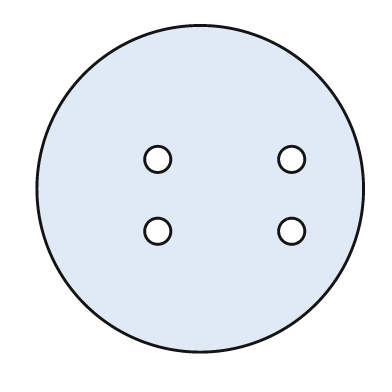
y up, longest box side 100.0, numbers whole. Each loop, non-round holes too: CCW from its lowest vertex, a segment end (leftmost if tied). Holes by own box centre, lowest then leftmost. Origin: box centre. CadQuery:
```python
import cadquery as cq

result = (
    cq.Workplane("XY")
    .moveTo(0.0, 0.0)
    .circle(50.0)
    .moveTo(-13.0, -13.0)
    .circle(4.0)
    .moveTo(28.0, -13.0)
    .circle(4.0)
    .moveTo(-13.0, 9.0)
    .circle(4.0)
    .moveTo(28.0, 9.0)
    .circle(4.0)
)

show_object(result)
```